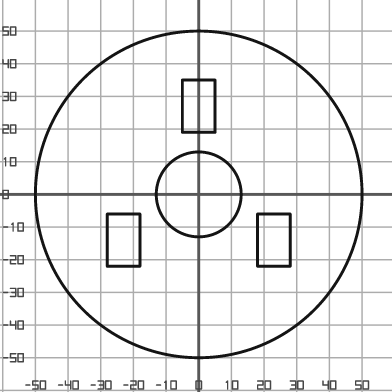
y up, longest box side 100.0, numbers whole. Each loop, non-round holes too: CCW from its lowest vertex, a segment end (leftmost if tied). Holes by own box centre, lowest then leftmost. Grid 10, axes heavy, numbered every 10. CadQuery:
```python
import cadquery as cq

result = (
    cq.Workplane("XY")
    .moveTo(0.0, 0.0)
    .circle(50.0)
    .moveTo(-28.0, -22.0)
    .lineTo(-18.0, -22.0)
    .lineTo(-18.0, -6.0)
    .lineTo(-28.0, -6.0)
    .close()
    .moveTo(18.0, -22.0)
    .lineTo(28.0, -22.0)
    .lineTo(28.0, -6.0)
    .lineTo(18.0, -6.0)
    .close()
    .moveTo(0.0, 0.0)
    .circle(13.0)
    .moveTo(-5.0, 19.0)
    .lineTo(5.0, 19.0)
    .lineTo(5.0, 35.0)
    .lineTo(-5.0, 35.0)
    .close()
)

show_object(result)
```